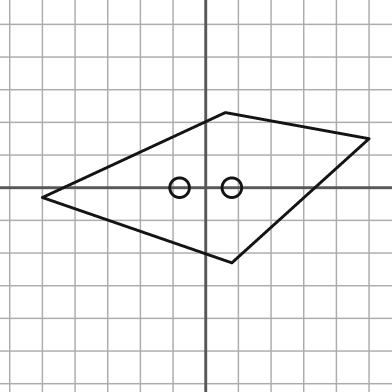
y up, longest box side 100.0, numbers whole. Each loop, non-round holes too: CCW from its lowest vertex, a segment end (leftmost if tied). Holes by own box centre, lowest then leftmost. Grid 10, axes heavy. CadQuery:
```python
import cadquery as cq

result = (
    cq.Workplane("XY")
    .moveTo(8.0, -23.0)
    .lineTo(50.0, 15.0)
    .lineTo(6.0, 23.0)
    .lineTo(-50.0, -3.0)
    .close()
    .moveTo(-8.0, 0.0)
    .circle(3.0)
    .moveTo(8.0, 0.0)
    .circle(3.0)
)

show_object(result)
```